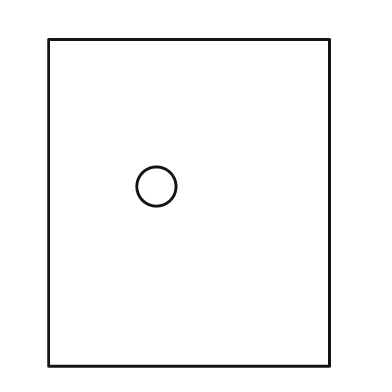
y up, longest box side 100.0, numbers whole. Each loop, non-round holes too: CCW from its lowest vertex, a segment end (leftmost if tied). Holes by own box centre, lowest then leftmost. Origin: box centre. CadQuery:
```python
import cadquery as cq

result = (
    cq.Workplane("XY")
    .moveTo(-43.0, -50.0)
    .lineTo(43.0, -50.0)
    .lineTo(43.0, 50.0)
    .lineTo(-43.0, 50.0)
    .close()
    .moveTo(-10.0, 5.0)
    .circle(6.0)
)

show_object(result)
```